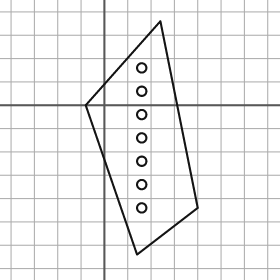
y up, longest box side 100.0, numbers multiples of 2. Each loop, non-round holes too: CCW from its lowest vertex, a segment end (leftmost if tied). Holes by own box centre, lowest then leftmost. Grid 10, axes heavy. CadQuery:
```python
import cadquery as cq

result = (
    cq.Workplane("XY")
    .moveTo(14.0, -64.0)
    .lineTo(40.0, -44.0)
    .lineTo(24.0, 36.0)
    .lineTo(-8.0, 0.0)
    .close()
    .moveTo(16.0, -44.0)
    .circle(2.0)
    .moveTo(16.0, -34.0)
    .circle(2.0)
    .moveTo(16.0, -24.0)
    .circle(2.0)
    .moveTo(16.0, -14.0)
    .circle(2.0)
    .moveTo(16.0, -4.0)
    .circle(2.0)
    .moveTo(16.0, 6.0)
    .circle(2.0)
    .moveTo(16.0, 16.0)
    .circle(2.0)
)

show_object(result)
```